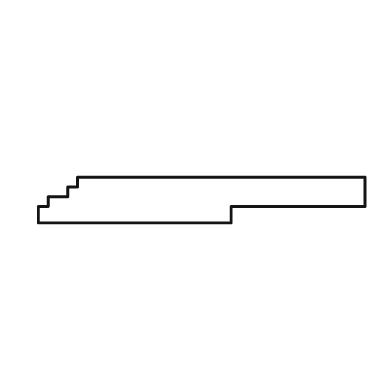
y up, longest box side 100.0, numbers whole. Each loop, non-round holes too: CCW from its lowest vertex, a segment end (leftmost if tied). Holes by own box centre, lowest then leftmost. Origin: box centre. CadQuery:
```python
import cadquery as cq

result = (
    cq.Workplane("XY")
    .moveTo(-50.0, -7.0)
    .lineTo(9.0, -7.0)
    .lineTo(9.0, -2.0)
    .lineTo(50.0, -2.0)
    .lineTo(50.0, 7.0)
    .lineTo(-38.0, 7.0)
    .lineTo(-38.0, 4.0)
    .lineTo(-41.0, 4.0)
    .lineTo(-41.0, 1.0)
    .lineTo(-47.0, 1.0)
    .lineTo(-47.0, -2.0)
    .lineTo(-50.0, -2.0)
    .close()
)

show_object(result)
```